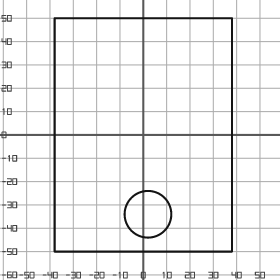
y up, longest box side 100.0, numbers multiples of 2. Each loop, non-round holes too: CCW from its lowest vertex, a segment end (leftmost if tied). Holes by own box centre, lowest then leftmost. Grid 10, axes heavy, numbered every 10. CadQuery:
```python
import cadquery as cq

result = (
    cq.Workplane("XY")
    .moveTo(-38.0, -50.0)
    .lineTo(38.0, -50.0)
    .lineTo(38.0, 50.0)
    .lineTo(-38.0, 50.0)
    .close()
    .moveTo(2.0, -34.0)
    .circle(10.0)
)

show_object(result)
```